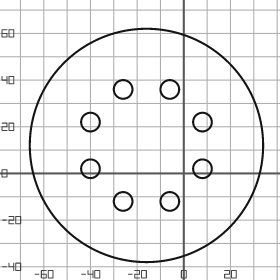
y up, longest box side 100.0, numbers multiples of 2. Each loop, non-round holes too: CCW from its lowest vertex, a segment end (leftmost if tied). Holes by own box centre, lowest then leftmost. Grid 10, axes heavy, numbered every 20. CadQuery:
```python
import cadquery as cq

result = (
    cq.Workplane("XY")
    .moveTo(-16.0, 12.0)
    .circle(50.0)
    .moveTo(-26.0, -12.0)
    .circle(4.0)
    .moveTo(-6.0, -12.0)
    .circle(4.0)
    .moveTo(-40.0, 2.0)
    .circle(4.0)
    .moveTo(8.0, 2.0)
    .circle(4.0)
    .moveTo(-40.0, 22.0)
    .circle(4.0)
    .moveTo(8.0, 22.0)
    .circle(4.0)
    .moveTo(-26.0, 36.0)
    .circle(4.0)
    .moveTo(-6.0, 36.0)
    .circle(4.0)
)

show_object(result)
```